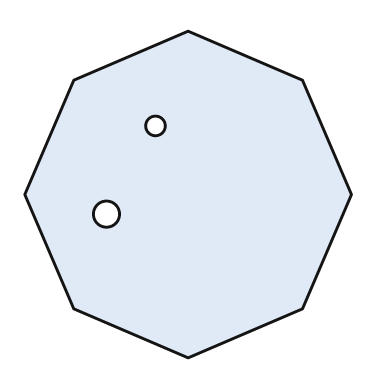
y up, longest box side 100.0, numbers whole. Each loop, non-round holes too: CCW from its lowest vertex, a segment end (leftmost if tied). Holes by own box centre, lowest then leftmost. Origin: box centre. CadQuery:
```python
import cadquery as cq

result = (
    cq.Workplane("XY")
    .moveTo(0.0, -50.0)
    .lineTo(35.0, -35.0)
    .lineTo(50.0, 0.0)
    .lineTo(35.0, 35.0)
    .lineTo(0.0, 50.0)
    .lineTo(-35.0, 35.0)
    .lineTo(-50.0, 0.0)
    .lineTo(-35.0, -35.0)
    .close()
    .moveTo(-25.0, -6.0)
    .circle(4.0)
    .moveTo(-10.0, 21.0)
    .circle(3.0)
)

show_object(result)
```